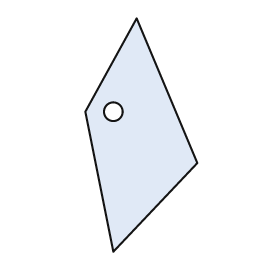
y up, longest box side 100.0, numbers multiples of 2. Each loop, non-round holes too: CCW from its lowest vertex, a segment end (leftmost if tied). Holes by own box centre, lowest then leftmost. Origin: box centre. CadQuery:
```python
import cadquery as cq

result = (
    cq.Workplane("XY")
    .moveTo(-12.0, -50.0)
    .lineTo(24.0, -12.0)
    .lineTo(-2.0, 50.0)
    .lineTo(-24.0, 10.0)
    .close()
    .moveTo(-12.0, 10.0)
    .circle(4.0)
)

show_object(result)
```